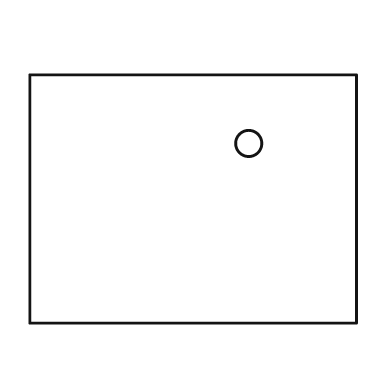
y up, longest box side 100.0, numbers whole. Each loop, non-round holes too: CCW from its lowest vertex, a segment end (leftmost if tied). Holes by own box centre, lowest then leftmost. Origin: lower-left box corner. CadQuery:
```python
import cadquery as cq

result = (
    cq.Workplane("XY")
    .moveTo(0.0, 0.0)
    .lineTo(100.0, 0.0)
    .lineTo(100.0, 76.0)
    .lineTo(0.0, 76.0)
    .close()
    .moveTo(67.0, 55.0)
    .circle(4.0)
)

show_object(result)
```